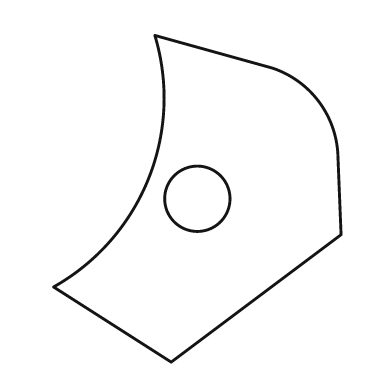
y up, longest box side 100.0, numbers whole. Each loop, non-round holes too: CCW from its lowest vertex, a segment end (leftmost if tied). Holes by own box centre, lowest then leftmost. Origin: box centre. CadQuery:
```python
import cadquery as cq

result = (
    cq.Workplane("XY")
    .moveTo(-8.0, -50.0)
    .lineTo(44.0, -11.0)
    .lineTo(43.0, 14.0)
    .threePointArc((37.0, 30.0), (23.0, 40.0))
    .lineTo(-13.0, 50.0)
    .threePointArc((-15.0, 6.0), (-44.0, -27.0))
    .close()
    .moveTo(0.0, 0.0)
    .circle(10.0)
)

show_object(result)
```